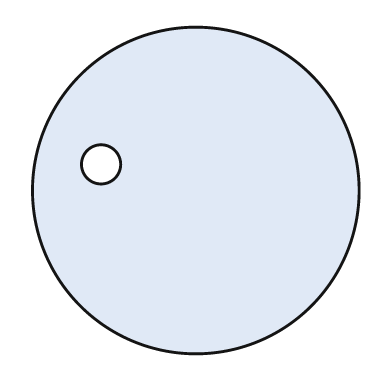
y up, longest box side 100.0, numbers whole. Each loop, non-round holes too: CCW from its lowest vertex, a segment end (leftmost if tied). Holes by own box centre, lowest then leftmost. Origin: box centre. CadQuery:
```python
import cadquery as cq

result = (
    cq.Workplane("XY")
    .moveTo(0.0, 0.0)
    .circle(50.0)
    .moveTo(-29.0, 8.0)
    .circle(6.0)
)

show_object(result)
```